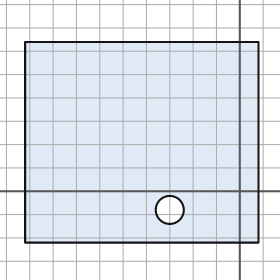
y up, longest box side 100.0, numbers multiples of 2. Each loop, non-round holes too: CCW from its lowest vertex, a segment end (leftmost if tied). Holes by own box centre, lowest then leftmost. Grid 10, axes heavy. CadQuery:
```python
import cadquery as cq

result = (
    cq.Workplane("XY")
    .moveTo(-92.0, -22.0)
    .lineTo(8.0, -22.0)
    .lineTo(8.0, 64.0)
    .lineTo(-92.0, 64.0)
    .close()
    .moveTo(-30.0, -8.0)
    .circle(6.0)
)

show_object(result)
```